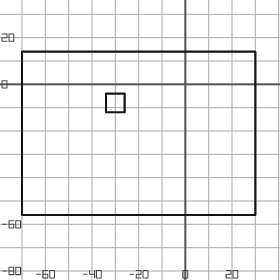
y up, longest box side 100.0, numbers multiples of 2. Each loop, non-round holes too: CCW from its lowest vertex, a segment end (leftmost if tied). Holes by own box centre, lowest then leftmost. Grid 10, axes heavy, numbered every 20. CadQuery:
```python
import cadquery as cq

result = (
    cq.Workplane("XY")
    .moveTo(-70.0, -56.0)
    .lineTo(30.0, -56.0)
    .lineTo(30.0, 14.0)
    .lineTo(-70.0, 14.0)
    .close()
    .moveTo(-34.0, -12.0)
    .lineTo(-26.0, -12.0)
    .lineTo(-26.0, -4.0)
    .lineTo(-34.0, -4.0)
    .close()
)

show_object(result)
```